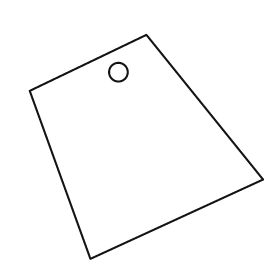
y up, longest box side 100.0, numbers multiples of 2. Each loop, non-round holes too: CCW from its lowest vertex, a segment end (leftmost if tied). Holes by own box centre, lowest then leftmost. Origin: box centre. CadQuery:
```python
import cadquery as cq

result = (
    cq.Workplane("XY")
    .moveTo(-24.0, -48.0)
    .lineTo(50.0, -14.0)
    .lineTo(0.0, 48.0)
    .lineTo(-50.0, 24.0)
    .close()
    .moveTo(-12.0, 32.0)
    .circle(4.0)
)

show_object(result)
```